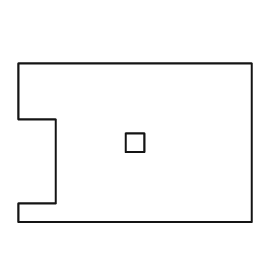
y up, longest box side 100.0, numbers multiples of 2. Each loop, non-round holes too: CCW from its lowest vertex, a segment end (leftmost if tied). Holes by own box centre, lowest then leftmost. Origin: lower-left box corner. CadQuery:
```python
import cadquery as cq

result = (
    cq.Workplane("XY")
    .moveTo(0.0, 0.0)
    .lineTo(100.0, 0.0)
    .lineTo(100.0, 68.0)
    .lineTo(0.0, 68.0)
    .lineTo(0.0, 44.0)
    .lineTo(16.0, 44.0)
    .lineTo(16.0, 8.0)
    .lineTo(0.0, 8.0)
    .close()
    .moveTo(46.0, 30.0)
    .lineTo(54.0, 30.0)
    .lineTo(54.0, 38.0)
    .lineTo(46.0, 38.0)
    .close()
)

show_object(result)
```